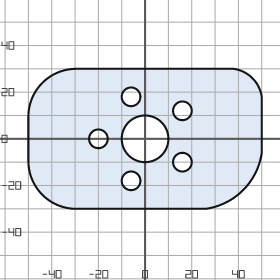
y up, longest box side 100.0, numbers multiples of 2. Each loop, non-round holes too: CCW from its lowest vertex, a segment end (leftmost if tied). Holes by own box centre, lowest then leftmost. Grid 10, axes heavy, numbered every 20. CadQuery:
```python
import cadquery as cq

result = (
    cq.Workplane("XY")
    .moveTo(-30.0, -30.0)
    .lineTo(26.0, -30.0)
    .threePointArc((42.0, -22.0), (50.0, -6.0))
    .lineTo(50.0, 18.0)
    .threePointArc((46.0, 26.0), (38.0, 30.0))
    .lineTo(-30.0, 30.0)
    .threePointArc((-44.0, 24.0), (-50.0, 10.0))
    .lineTo(-50.0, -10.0)
    .threePointArc((-44.0, -24.0), (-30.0, -30.0))
    .close()
    .moveTo(-6.0, -18.0)
    .circle(4.0)
    .moveTo(16.0, -10.0)
    .circle(4.0)
    .moveTo(-20.0, 0.0)
    .circle(4.0)
    .moveTo(0.0, 0.0)
    .circle(10.0)
    .moveTo(16.0, 12.0)
    .circle(4.0)
    .moveTo(-6.0, 18.0)
    .circle(4.0)
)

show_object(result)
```